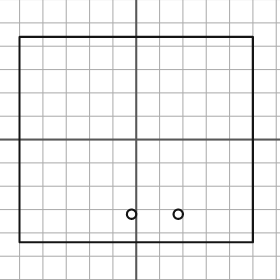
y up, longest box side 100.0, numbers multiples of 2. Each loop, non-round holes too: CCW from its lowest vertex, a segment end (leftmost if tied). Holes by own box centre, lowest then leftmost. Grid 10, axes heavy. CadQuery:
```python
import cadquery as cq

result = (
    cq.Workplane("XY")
    .moveTo(-50.0, -44.0)
    .lineTo(50.0, -44.0)
    .lineTo(50.0, 44.0)
    .lineTo(-50.0, 44.0)
    .close()
    .moveTo(-2.0, -32.0)
    .circle(2.0)
    .moveTo(18.0, -32.0)
    .circle(2.0)
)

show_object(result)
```